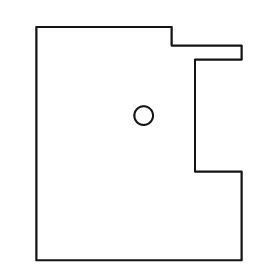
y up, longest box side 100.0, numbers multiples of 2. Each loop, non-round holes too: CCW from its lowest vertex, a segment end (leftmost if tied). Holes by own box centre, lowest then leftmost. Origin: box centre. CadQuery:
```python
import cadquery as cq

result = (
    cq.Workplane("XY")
    .moveTo(-44.0, -50.0)
    .lineTo(44.0, -50.0)
    .lineTo(44.0, -12.0)
    .lineTo(24.0, -12.0)
    .lineTo(24.0, 36.0)
    .lineTo(44.0, 36.0)
    .lineTo(44.0, 42.0)
    .lineTo(14.0, 42.0)
    .lineTo(14.0, 50.0)
    .lineTo(-44.0, 50.0)
    .close()
    .moveTo(2.0, 12.0)
    .circle(4.0)
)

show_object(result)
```